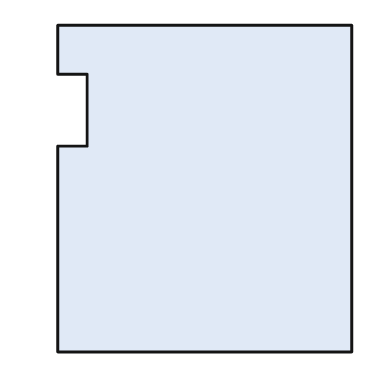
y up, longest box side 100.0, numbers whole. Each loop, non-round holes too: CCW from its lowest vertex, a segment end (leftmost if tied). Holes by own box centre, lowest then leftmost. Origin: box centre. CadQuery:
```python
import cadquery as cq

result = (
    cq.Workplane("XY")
    .moveTo(-45.0, -50.0)
    .lineTo(45.0, -50.0)
    .lineTo(45.0, 50.0)
    .lineTo(-45.0, 50.0)
    .lineTo(-45.0, 35.0)
    .lineTo(-36.0, 35.0)
    .lineTo(-36.0, 13.0)
    .lineTo(-45.0, 13.0)
    .close()
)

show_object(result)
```